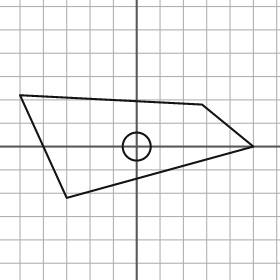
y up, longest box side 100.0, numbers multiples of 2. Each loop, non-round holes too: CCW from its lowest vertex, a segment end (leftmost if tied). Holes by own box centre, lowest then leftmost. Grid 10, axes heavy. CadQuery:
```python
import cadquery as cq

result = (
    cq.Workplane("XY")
    .moveTo(-30.0, -22.0)
    .lineTo(50.0, 0.0)
    .lineTo(28.0, 18.0)
    .lineTo(-50.0, 22.0)
    .close()
    .moveTo(0.0, 0.0)
    .circle(6.0)
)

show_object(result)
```